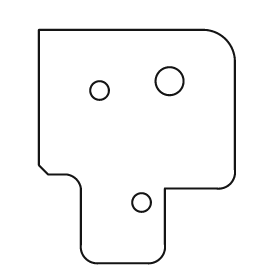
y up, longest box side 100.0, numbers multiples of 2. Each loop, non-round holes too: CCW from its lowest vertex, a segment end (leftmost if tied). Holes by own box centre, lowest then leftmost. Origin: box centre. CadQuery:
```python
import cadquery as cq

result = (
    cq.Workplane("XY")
    .moveTo(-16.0, -50.0)
    .lineTo(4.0, -50.0)
    .threePointArc((10.0, -48.0), (12.0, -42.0))
    .lineTo(12.0, -18.0)
    .lineTo(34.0, -18.0)
    .threePointArc((40.0, -16.0), (42.0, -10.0))
    .lineTo(42.0, 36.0)
    .threePointArc((38.0, 46.0), (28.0, 50.0))
    .lineTo(-42.0, 50.0)
    .lineTo(-42.0, -8.0)
    .lineTo(-38.0, -12.0)
    .lineTo(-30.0, -12.0)
    .threePointArc((-26.0, -14.0), (-24.0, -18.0))
    .lineTo(-24.0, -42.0)
    .threePointArc((-22.0, -48.0), (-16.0, -50.0))
    .close()
    .moveTo(2.0, -24.0)
    .circle(4.0)
    .moveTo(-16.0, 24.0)
    .circle(4.0)
    .moveTo(14.0, 28.0)
    .circle(6.0)
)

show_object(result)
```